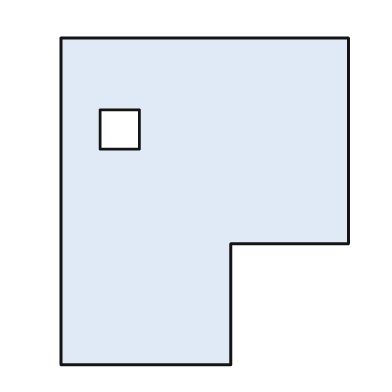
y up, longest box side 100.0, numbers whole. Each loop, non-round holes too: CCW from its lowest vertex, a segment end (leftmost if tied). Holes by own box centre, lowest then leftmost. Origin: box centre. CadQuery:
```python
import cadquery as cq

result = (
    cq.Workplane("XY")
    .moveTo(-44.0, -50.0)
    .lineTo(8.0, -50.0)
    .lineTo(8.0, -13.0)
    .lineTo(44.0, -13.0)
    .lineTo(44.0, 50.0)
    .lineTo(-44.0, 50.0)
    .close()
    .moveTo(-32.0, 16.0)
    .lineTo(-20.0, 16.0)
    .lineTo(-20.0, 28.0)
    .lineTo(-32.0, 28.0)
    .close()
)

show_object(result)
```